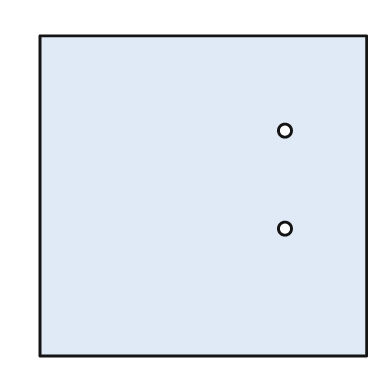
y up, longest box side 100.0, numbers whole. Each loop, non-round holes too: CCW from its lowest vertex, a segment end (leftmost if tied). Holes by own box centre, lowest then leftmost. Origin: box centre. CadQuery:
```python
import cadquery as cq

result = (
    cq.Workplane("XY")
    .moveTo(-50.0, -49.0)
    .lineTo(50.0, -49.0)
    .lineTo(50.0, 49.0)
    .lineTo(-50.0, 49.0)
    .close()
    .moveTo(25.0, -10.0)
    .circle(2.0)
    .moveTo(25.0, 20.0)
    .circle(2.0)
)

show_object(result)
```